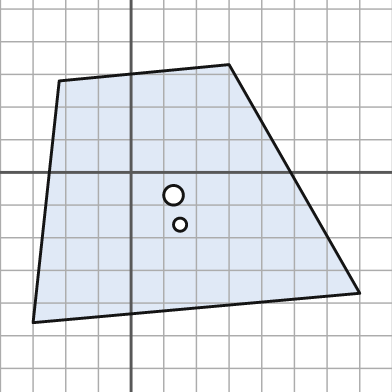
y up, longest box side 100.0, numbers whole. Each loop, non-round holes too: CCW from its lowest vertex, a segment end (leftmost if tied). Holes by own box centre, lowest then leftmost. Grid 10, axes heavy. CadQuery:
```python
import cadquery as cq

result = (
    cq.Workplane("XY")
    .moveTo(-30.0, -46.0)
    .lineTo(70.0, -37.0)
    .lineTo(30.0, 33.0)
    .lineTo(-22.0, 28.0)
    .close()
    .moveTo(15.0, -16.0)
    .circle(2.0)
    .moveTo(13.0, -7.0)
    .circle(3.0)
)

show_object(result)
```